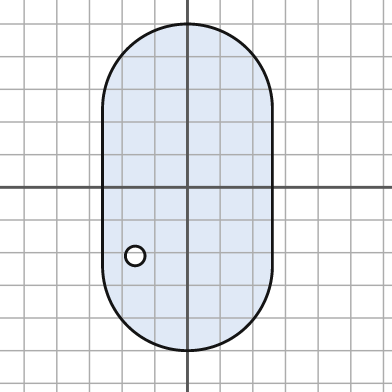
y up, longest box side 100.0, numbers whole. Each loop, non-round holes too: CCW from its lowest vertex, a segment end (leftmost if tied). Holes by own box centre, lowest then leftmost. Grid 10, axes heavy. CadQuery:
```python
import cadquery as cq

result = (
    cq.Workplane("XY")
    .moveTo(-26.0, -24.0)
    .threePointArc((0.0, -50.0), (26.0, -24.0))
    .lineTo(26.0, 24.0)
    .threePointArc((0.0, 50.0), (-26.0, 24.0))
    .close()
    .moveTo(-16.0, -21.0)
    .circle(3.0)
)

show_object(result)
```